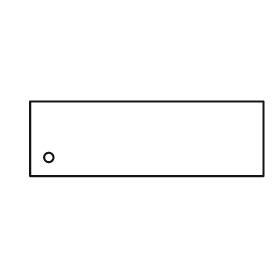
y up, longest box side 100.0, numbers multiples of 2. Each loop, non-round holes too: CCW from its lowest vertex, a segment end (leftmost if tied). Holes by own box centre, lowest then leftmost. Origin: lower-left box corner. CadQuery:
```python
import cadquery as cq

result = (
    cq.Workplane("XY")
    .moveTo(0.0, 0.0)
    .lineTo(100.0, 0.0)
    .lineTo(100.0, 32.0)
    .lineTo(0.0, 32.0)
    .close()
    .moveTo(8.0, 8.0)
    .circle(2.0)
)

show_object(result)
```